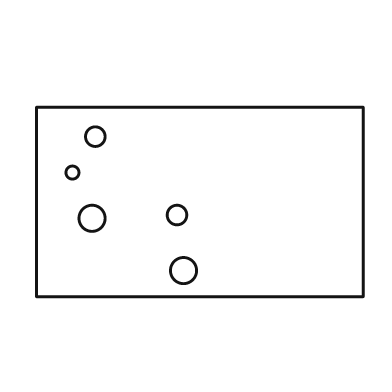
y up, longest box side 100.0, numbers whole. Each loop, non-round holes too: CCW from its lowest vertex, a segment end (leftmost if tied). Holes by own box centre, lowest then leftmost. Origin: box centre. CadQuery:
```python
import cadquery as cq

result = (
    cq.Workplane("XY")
    .moveTo(-50.0, -29.0)
    .lineTo(50.0, -29.0)
    .lineTo(50.0, 29.0)
    .lineTo(-50.0, 29.0)
    .close()
    .moveTo(-5.0, -21.0)
    .circle(4.0)
    .moveTo(-33.0, -5.0)
    .circle(4.0)
    .moveTo(-7.0, -4.0)
    .circle(3.0)
    .moveTo(-39.0, 9.0)
    .circle(2.0)
    .moveTo(-32.0, 20.0)
    .circle(3.0)
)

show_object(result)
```